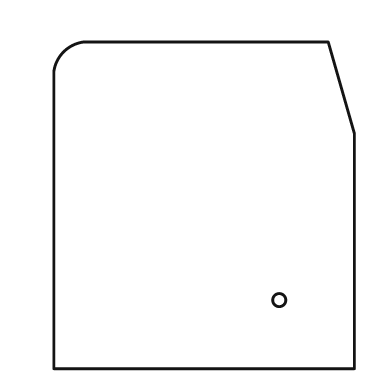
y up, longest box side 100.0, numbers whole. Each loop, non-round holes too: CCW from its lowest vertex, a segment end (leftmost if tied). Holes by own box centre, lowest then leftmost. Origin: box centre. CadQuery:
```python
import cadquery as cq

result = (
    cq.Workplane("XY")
    .moveTo(-46.0, -50.0)
    .lineTo(46.0, -50.0)
    .lineTo(46.0, 22.0)
    .lineTo(38.0, 50.0)
    .lineTo(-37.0, 50.0)
    .threePointArc((-43.0, 47.0), (-46.0, 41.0))
    .close()
    .moveTo(23.0, -29.0)
    .circle(2.0)
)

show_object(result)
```